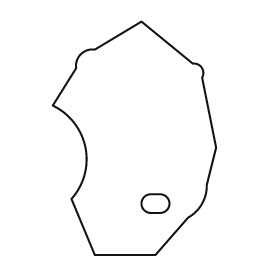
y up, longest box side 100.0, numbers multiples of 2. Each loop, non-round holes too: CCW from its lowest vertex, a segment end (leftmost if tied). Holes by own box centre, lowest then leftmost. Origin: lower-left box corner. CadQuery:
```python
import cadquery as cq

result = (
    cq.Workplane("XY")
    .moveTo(18.0, 0.0)
    .lineTo(44.0, 0.0)
    .lineTo(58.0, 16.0)
    .threePointArc((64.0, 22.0), (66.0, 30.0))
    .lineTo(70.0, 46.0)
    .lineTo(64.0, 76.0)
    .threePointArc((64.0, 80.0), (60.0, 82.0))
    .lineTo(38.0, 100.0)
    .lineTo(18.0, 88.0)
    .threePointArc((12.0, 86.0), (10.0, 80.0))
    .lineTo(0.0, 64.0)
    .threePointArc((14.0, 46.0), (8.0, 24.0))
    .close()
    .moveTo(42.0, 18.0)
    .lineTo(46.0, 18.0)
    .threePointArc((50.0, 22.0), (46.0, 26.0))
    .lineTo(42.0, 26.0)
    .threePointArc((38.0, 22.0), (42.0, 18.0))
    .close()
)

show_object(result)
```